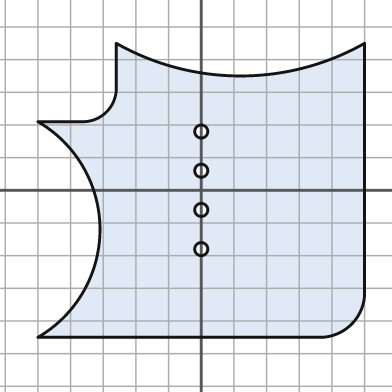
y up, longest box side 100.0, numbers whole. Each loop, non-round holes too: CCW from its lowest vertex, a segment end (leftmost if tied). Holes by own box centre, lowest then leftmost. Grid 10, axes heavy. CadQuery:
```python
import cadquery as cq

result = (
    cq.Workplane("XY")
    .moveTo(-50.0, -45.0)
    .lineTo(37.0, -45.0)
    .threePointArc((46.0, -41.0), (50.0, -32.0))
    .lineTo(50.0, 45.0)
    .threePointArc((12.0, 35.0), (-26.0, 45.0))
    .lineTo(-26.0, 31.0)
    .threePointArc((-29.0, 24.0), (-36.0, 21.0))
    .lineTo(-50.0, 21.0)
    .threePointArc((-31.0, -12.0), (-50.0, -45.0))
    .close()
    .moveTo(0.0, -18.0)
    .circle(2.0)
    .moveTo(0.0, -6.0)
    .circle(2.0)
    .moveTo(0.0, 6.0)
    .circle(2.0)
    .moveTo(0.0, 18.0)
    .circle(2.0)
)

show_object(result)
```